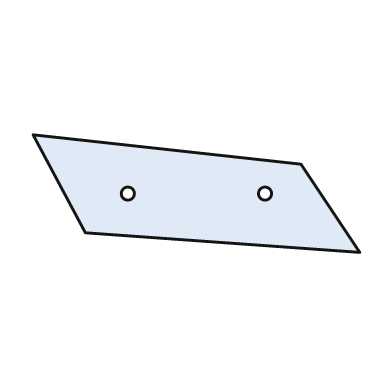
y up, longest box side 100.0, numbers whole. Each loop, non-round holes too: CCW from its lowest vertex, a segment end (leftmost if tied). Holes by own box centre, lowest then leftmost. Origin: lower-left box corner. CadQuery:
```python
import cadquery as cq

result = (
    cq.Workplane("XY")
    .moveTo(100.0, 0.0)
    .lineTo(82.0, 27.0)
    .lineTo(0.0, 36.0)
    .lineTo(16.0, 6.0)
    .close()
    .moveTo(29.0, 18.0)
    .circle(2.0)
    .moveTo(71.0, 18.0)
    .circle(2.0)
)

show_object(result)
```